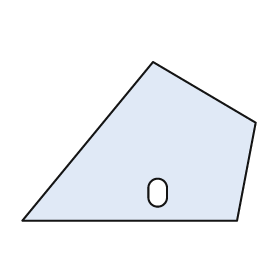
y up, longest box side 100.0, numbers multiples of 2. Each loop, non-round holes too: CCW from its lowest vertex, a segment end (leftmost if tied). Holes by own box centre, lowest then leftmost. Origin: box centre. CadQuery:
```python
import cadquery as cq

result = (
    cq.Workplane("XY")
    .moveTo(-50.0, -34.0)
    .lineTo(42.0, -34.0)
    .lineTo(50.0, 8.0)
    .lineTo(6.0, 34.0)
    .close()
    .moveTo(4.0, -24.0)
    .threePointArc((8.0, -28.0), (12.0, -24.0))
    .lineTo(12.0, -20.0)
    .threePointArc((8.0, -16.0), (4.0, -20.0))
    .close()
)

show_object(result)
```